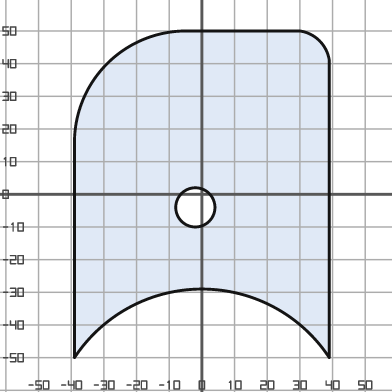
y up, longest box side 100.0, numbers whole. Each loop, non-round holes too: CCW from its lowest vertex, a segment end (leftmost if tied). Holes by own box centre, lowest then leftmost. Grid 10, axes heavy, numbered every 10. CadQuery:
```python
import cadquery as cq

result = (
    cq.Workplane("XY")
    .moveTo(-39.0, -50.0)
    .threePointArc((0.0, -29.0), (39.0, -50.0))
    .lineTo(39.0, 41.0)
    .threePointArc((36.0, 47.0), (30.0, 50.0))
    .lineTo(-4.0, 50.0)
    .threePointArc((-29.0, 40.0), (-39.0, 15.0))
    .close()
    .moveTo(-2.0, -4.0)
    .circle(6.0)
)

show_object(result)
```